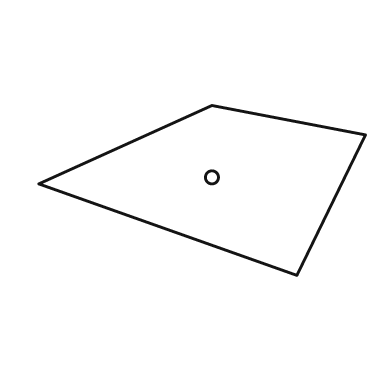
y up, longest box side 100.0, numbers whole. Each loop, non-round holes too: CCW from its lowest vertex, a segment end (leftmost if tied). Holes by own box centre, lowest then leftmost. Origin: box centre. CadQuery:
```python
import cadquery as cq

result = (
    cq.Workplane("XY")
    .moveTo(29.0, -26.0)
    .lineTo(50.0, 17.0)
    .lineTo(3.0, 26.0)
    .lineTo(-50.0, 2.0)
    .close()
    .moveTo(3.0, 4.0)
    .circle(2.0)
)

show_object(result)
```